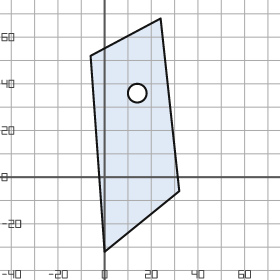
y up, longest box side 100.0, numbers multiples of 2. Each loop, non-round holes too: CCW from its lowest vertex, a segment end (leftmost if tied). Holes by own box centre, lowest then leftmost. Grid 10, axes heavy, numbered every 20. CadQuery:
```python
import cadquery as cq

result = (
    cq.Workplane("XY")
    .moveTo(0.0, -32.0)
    .lineTo(32.0, -6.0)
    .lineTo(24.0, 68.0)
    .lineTo(-6.0, 52.0)
    .close()
    .moveTo(14.0, 36.0)
    .circle(4.0)
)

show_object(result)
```